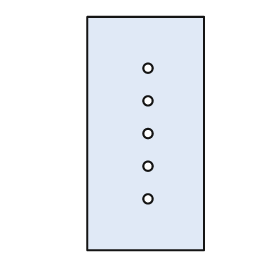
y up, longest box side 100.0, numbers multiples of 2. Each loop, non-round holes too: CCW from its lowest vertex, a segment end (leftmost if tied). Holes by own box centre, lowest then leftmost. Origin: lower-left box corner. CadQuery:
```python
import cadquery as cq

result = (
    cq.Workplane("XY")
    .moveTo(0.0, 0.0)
    .lineTo(50.0, 0.0)
    .lineTo(50.0, 100.0)
    .lineTo(0.0, 100.0)
    .close()
    .moveTo(26.0, 22.0)
    .circle(2.0)
    .moveTo(26.0, 36.0)
    .circle(2.0)
    .moveTo(26.0, 50.0)
    .circle(2.0)
    .moveTo(26.0, 64.0)
    .circle(2.0)
    .moveTo(26.0, 78.0)
    .circle(2.0)
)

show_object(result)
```